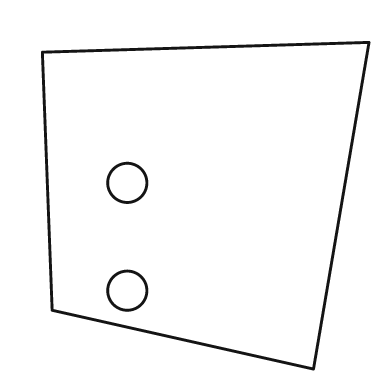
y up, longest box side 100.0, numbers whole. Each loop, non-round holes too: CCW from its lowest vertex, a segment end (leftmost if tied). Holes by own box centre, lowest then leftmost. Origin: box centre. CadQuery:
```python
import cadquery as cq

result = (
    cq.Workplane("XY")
    .moveTo(33.0, -50.0)
    .lineTo(50.0, 50.0)
    .lineTo(-50.0, 47.0)
    .lineTo(-47.0, -32.0)
    .close()
    .moveTo(-24.0, -26.0)
    .circle(6.0)
    .moveTo(-24.0, 7.0)
    .circle(6.0)
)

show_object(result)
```